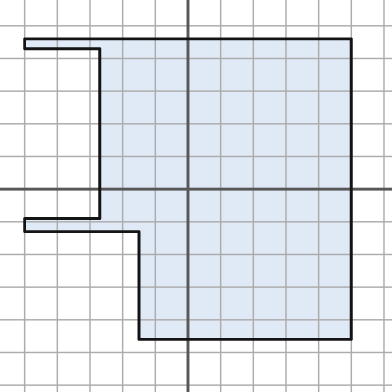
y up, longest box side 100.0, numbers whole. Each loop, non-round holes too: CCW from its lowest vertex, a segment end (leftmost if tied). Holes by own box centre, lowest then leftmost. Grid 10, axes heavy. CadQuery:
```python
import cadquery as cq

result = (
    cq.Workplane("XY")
    .moveTo(-15.0, -46.0)
    .lineTo(50.0, -46.0)
    .lineTo(50.0, 46.0)
    .lineTo(-50.0, 46.0)
    .lineTo(-50.0, 43.0)
    .lineTo(-27.0, 43.0)
    .lineTo(-27.0, -9.0)
    .lineTo(-50.0, -9.0)
    .lineTo(-50.0, -13.0)
    .lineTo(-15.0, -13.0)
    .close()
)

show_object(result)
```